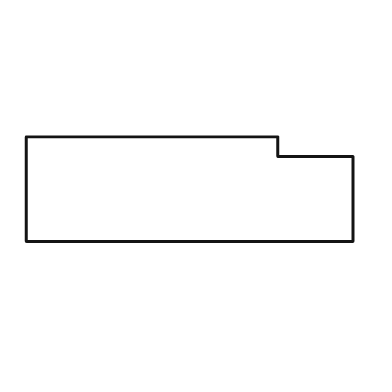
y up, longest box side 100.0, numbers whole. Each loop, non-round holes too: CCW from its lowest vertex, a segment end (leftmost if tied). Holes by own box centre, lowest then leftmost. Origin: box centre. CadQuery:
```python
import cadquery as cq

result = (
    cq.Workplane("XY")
    .moveTo(-50.0, -16.0)
    .lineTo(50.0, -16.0)
    .lineTo(50.0, 10.0)
    .lineTo(27.0, 10.0)
    .lineTo(27.0, 16.0)
    .lineTo(-50.0, 16.0)
    .close()
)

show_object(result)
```